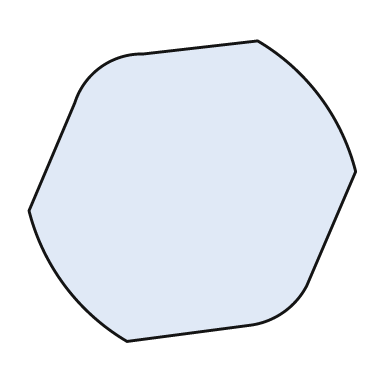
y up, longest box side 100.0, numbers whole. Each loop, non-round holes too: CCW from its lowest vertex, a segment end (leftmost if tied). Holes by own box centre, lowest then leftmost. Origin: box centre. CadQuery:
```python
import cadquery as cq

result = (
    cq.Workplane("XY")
    .moveTo(-20.0, -46.0)
    .lineTo(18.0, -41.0)
    .threePointArc((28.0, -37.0), (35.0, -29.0))
    .lineTo(50.0, 6.0)
    .threePointArc((39.0, 29.0), (20.0, 46.0))
    .lineTo(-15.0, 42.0)
    .threePointArc((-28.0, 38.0), (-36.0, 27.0))
    .lineTo(-50.0, -6.0)
    .threePointArc((-39.0, -29.0), (-20.0, -46.0))
    .close()
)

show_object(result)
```